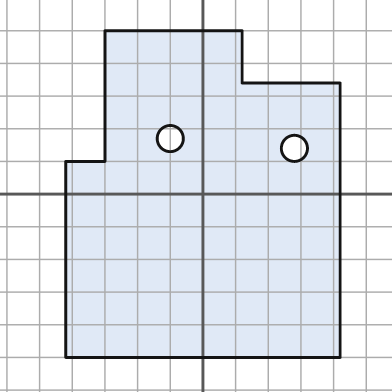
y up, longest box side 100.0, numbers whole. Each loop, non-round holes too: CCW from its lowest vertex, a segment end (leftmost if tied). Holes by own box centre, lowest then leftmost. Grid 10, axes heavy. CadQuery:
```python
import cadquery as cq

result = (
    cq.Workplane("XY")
    .moveTo(-42.0, -50.0)
    .lineTo(42.0, -50.0)
    .lineTo(42.0, 34.0)
    .lineTo(12.0, 34.0)
    .lineTo(12.0, 50.0)
    .lineTo(-30.0, 50.0)
    .lineTo(-30.0, 10.0)
    .lineTo(-42.0, 10.0)
    .close()
    .moveTo(28.0, 14.0)
    .circle(4.0)
    .moveTo(-10.0, 17.0)
    .circle(4.0)
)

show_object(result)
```